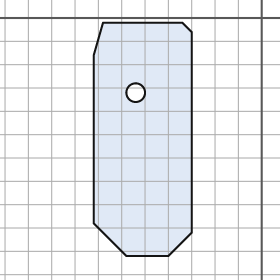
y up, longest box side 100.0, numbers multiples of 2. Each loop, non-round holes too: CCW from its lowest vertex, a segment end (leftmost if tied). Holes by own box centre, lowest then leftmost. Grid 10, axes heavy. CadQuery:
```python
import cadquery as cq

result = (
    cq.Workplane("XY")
    .moveTo(-58.0, -102.0)
    .lineTo(-40.0, -102.0)
    .lineTo(-30.0, -92.0)
    .lineTo(-30.0, -6.0)
    .lineTo(-34.0, -2.0)
    .lineTo(-68.0, -2.0)
    .lineTo(-72.0, -16.0)
    .lineTo(-72.0, -88.0)
    .close()
    .moveTo(-54.0, -32.0)
    .circle(4.0)
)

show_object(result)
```